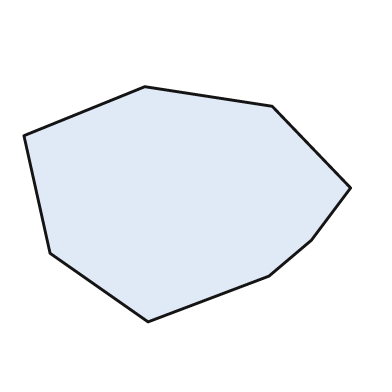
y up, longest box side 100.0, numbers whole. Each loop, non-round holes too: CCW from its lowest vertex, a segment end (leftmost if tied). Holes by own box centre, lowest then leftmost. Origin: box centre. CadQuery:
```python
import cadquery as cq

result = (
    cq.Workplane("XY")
    .moveTo(-12.0, -36.0)
    .lineTo(25.0, -22.0)
    .lineTo(38.0, -11.0)
    .lineTo(50.0, 5.0)
    .lineTo(26.0, 30.0)
    .lineTo(-13.0, 36.0)
    .lineTo(-50.0, 21.0)
    .lineTo(-42.0, -15.0)
    .close()
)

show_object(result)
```